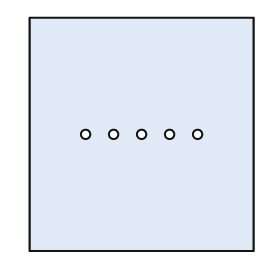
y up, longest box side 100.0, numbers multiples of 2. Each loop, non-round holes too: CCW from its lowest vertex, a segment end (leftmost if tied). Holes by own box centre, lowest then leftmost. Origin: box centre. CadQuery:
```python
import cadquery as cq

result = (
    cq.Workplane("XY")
    .moveTo(-48.0, -50.0)
    .lineTo(48.0, -50.0)
    .lineTo(48.0, 50.0)
    .lineTo(-48.0, 50.0)
    .close()
    .moveTo(-24.0, 0.0)
    .circle(2.0)
    .moveTo(-12.0, 0.0)
    .circle(2.0)
    .moveTo(0.0, 0.0)
    .circle(2.0)
    .moveTo(12.0, 0.0)
    .circle(2.0)
    .moveTo(24.0, 0.0)
    .circle(2.0)
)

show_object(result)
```